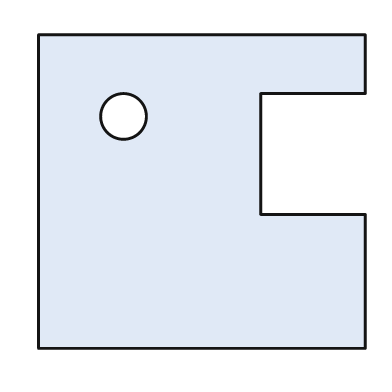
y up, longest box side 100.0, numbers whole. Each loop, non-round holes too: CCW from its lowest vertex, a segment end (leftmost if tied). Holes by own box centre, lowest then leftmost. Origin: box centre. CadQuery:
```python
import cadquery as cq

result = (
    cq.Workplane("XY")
    .moveTo(-50.0, -48.0)
    .lineTo(50.0, -48.0)
    .lineTo(50.0, -7.0)
    .lineTo(18.0, -7.0)
    .lineTo(18.0, 30.0)
    .lineTo(50.0, 30.0)
    .lineTo(50.0, 48.0)
    .lineTo(-50.0, 48.0)
    .close()
    .moveTo(-24.0, 23.0)
    .circle(7.0)
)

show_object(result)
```